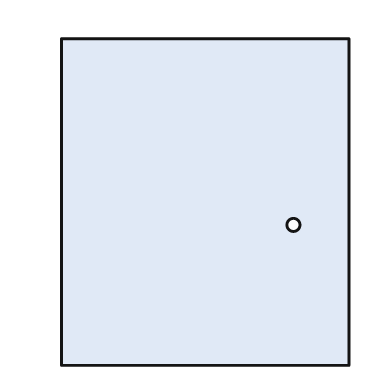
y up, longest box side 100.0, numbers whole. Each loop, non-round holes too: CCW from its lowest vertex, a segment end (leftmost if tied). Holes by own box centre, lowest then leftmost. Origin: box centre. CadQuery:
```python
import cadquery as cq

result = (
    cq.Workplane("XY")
    .moveTo(-44.0, -50.0)
    .lineTo(44.0, -50.0)
    .lineTo(44.0, 50.0)
    .lineTo(-44.0, 50.0)
    .close()
    .moveTo(27.0, -7.0)
    .circle(2.0)
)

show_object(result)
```